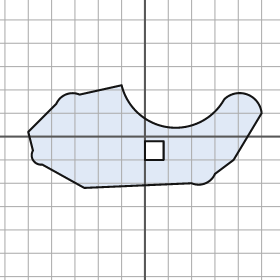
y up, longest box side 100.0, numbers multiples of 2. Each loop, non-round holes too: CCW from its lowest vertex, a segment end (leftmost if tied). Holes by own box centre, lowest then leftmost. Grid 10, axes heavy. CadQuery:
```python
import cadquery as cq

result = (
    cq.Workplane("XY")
    .moveTo(-26.0, -22.0)
    .lineTo(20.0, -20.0)
    .threePointArc((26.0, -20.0), (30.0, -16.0))
    .lineTo(38.0, -10.0)
    .lineTo(50.0, 10.0)
    .threePointArc((44.0, 18.0), (34.0, 16.0))
    .threePointArc((10.0, 4.0), (-10.0, 22.0))
    .lineTo(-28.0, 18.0)
    .threePointArc((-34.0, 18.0), (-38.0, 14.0))
    .lineTo(-50.0, 2.0)
    .lineTo(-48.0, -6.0)
    .threePointArc((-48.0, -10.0), (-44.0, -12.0))
    .close()
    .moveTo(0.0, -10.0)
    .lineTo(8.0, -10.0)
    .lineTo(8.0, -2.0)
    .lineTo(0.0, -2.0)
    .close()
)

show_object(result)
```